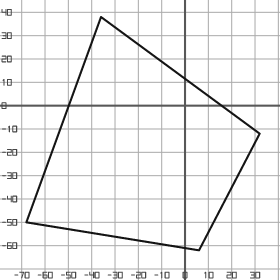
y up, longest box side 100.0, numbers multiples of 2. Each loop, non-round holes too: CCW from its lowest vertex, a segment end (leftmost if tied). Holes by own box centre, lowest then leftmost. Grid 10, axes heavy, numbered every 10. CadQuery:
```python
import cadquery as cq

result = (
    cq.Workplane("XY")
    .moveTo(6.0, -62.0)
    .lineTo(32.0, -12.0)
    .lineTo(-36.0, 38.0)
    .lineTo(-68.0, -50.0)
    .close()
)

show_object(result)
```